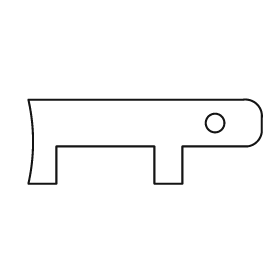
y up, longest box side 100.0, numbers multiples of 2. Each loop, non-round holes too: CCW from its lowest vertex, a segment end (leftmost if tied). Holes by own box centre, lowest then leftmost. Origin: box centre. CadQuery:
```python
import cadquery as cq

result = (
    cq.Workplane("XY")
    .moveTo(-50.0, -18.0)
    .lineTo(-38.0, -18.0)
    .lineTo(-38.0, -2.0)
    .lineTo(4.0, -2.0)
    .lineTo(4.0, -18.0)
    .lineTo(16.0, -18.0)
    .lineTo(16.0, -2.0)
    .lineTo(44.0, -2.0)
    .threePointArc((48.0, 0.0), (50.0, 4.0))
    .lineTo(50.0, 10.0)
    .threePointArc((48.0, 16.0), (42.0, 18.0))
    .lineTo(-50.0, 18.0)
    .threePointArc((-48.0, 0.0), (-50.0, -18.0))
    .close()
    .moveTo(30.0, 8.0)
    .circle(4.0)
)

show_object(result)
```